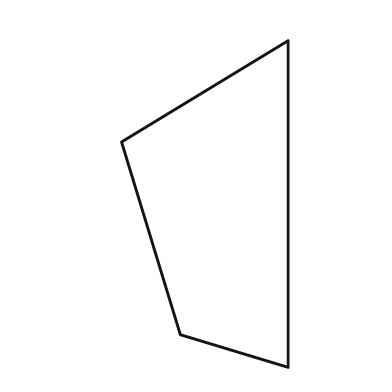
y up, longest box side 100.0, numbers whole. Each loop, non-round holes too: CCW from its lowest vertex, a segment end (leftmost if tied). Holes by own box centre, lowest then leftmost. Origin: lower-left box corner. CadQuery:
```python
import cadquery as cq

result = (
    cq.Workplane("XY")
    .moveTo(51.0, 0.0)
    .lineTo(51.0, 100.0)
    .lineTo(0.0, 69.0)
    .lineTo(18.0, 10.0)
    .close()
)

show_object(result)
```